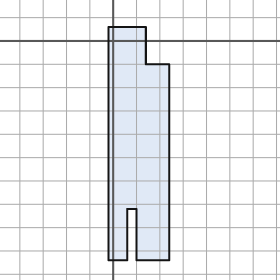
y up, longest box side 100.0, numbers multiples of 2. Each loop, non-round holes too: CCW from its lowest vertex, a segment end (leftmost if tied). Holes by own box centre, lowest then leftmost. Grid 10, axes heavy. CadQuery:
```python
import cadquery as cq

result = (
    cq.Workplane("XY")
    .moveTo(-2.0, -94.0)
    .lineTo(6.0, -94.0)
    .lineTo(6.0, -72.0)
    .lineTo(10.0, -72.0)
    .lineTo(10.0, -94.0)
    .lineTo(24.0, -94.0)
    .lineTo(24.0, -10.0)
    .lineTo(14.0, -10.0)
    .lineTo(14.0, 6.0)
    .lineTo(-2.0, 6.0)
    .close()
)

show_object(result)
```